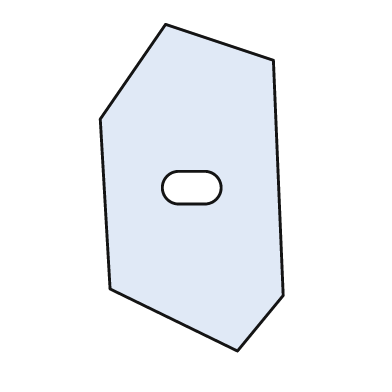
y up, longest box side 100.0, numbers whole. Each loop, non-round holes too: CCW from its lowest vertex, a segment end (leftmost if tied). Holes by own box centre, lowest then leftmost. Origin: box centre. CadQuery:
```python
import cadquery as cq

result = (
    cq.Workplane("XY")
    .moveTo(14.0, -50.0)
    .lineTo(28.0, -33.0)
    .lineTo(25.0, 39.0)
    .lineTo(-8.0, 50.0)
    .lineTo(-28.0, 21.0)
    .lineTo(-25.0, -31.0)
    .close()
    .moveTo(-4.0, -5.0)
    .lineTo(4.0, -5.0)
    .threePointArc((9.0, 0.0), (4.0, 5.0))
    .lineTo(-4.0, 5.0)
    .threePointArc((-9.0, 0.0), (-4.0, -5.0))
    .close()
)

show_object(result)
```